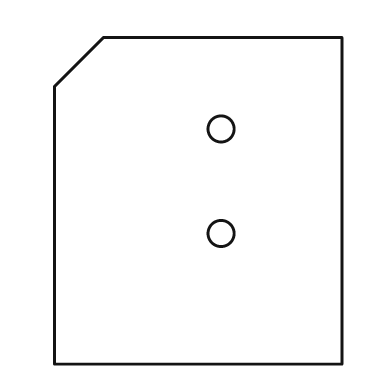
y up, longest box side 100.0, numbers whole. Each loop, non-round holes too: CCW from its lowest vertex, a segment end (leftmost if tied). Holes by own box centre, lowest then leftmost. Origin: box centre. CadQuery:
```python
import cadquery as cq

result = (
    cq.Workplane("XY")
    .moveTo(-44.0, -50.0)
    .lineTo(44.0, -50.0)
    .lineTo(44.0, 50.0)
    .lineTo(-29.0, 50.0)
    .lineTo(-44.0, 35.0)
    .close()
    .moveTo(7.0, -10.0)
    .circle(4.0)
    .moveTo(7.0, 22.0)
    .circle(4.0)
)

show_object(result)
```